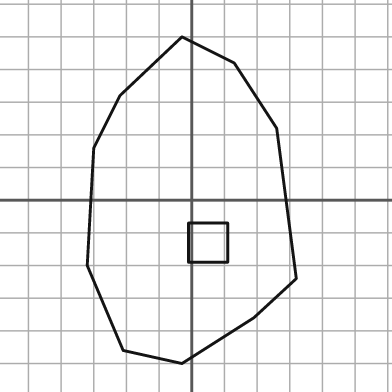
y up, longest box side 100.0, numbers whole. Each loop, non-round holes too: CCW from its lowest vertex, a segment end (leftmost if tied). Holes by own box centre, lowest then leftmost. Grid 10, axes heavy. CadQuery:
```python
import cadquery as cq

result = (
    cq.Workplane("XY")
    .moveTo(-3.0, -50.0)
    .lineTo(19.0, -36.0)
    .lineTo(32.0, -24.0)
    .lineTo(26.0, 22.0)
    .lineTo(13.0, 42.0)
    .lineTo(-3.0, 50.0)
    .lineTo(-22.0, 32.0)
    .lineTo(-30.0, 16.0)
    .lineTo(-32.0, -20.0)
    .lineTo(-21.0, -46.0)
    .close()
    .moveTo(-1.0, -19.0)
    .lineTo(11.0, -19.0)
    .lineTo(11.0, -7.0)
    .lineTo(-1.0, -7.0)
    .close()
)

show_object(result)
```